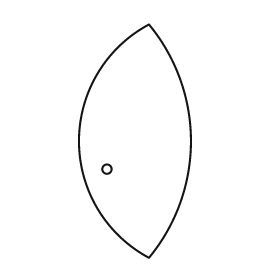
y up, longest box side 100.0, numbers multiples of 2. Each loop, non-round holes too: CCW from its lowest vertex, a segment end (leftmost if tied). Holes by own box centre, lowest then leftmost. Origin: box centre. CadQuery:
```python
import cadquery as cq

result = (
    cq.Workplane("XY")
    .moveTo(6.0, -50.0)
    .threePointArc((24.0, 0.0), (6.0, 50.0))
    .threePointArc((-24.0, 0.0), (6.0, -50.0))
    .close()
    .moveTo(-12.0, -12.0)
    .circle(2.0)
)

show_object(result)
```